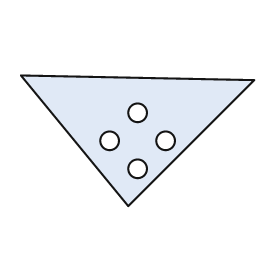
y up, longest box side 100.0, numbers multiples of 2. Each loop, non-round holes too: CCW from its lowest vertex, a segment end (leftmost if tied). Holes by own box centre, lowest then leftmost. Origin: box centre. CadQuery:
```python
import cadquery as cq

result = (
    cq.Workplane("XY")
    .moveTo(-4.0, -28.0)
    .lineTo(50.0, 26.0)
    .lineTo(-50.0, 28.0)
    .close()
    .moveTo(0.0, -12.0)
    .circle(4.0)
    .moveTo(-12.0, 0.0)
    .circle(4.0)
    .moveTo(12.0, 0.0)
    .circle(4.0)
    .moveTo(0.0, 12.0)
    .circle(4.0)
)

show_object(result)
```